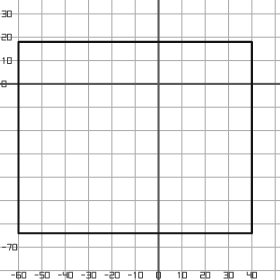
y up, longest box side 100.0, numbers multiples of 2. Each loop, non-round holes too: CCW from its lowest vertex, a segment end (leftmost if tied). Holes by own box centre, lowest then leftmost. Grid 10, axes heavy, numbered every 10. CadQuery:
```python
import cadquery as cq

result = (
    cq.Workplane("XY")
    .moveTo(-60.0, -64.0)
    .lineTo(40.0, -64.0)
    .lineTo(40.0, 18.0)
    .lineTo(-60.0, 18.0)
    .close()
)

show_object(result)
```